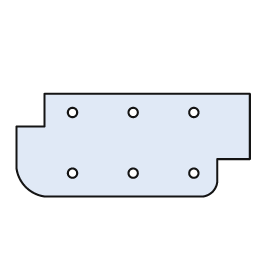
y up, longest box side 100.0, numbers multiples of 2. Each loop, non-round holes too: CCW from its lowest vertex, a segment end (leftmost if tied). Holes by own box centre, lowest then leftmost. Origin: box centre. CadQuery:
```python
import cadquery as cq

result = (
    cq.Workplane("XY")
    .moveTo(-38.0, -22.0)
    .lineTo(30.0, -22.0)
    .threePointArc((34.0, -20.0), (36.0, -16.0))
    .lineTo(36.0, -6.0)
    .lineTo(50.0, -6.0)
    .lineTo(50.0, 22.0)
    .lineTo(-38.0, 22.0)
    .lineTo(-38.0, 8.0)
    .lineTo(-50.0, 8.0)
    .lineTo(-50.0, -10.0)
    .threePointArc((-46.0, -18.0), (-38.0, -22.0))
    .close()
    .moveTo(-26.0, -12.0)
    .circle(2.0)
    .moveTo(0.0, -12.0)
    .circle(2.0)
    .moveTo(26.0, -12.0)
    .circle(2.0)
    .moveTo(-26.0, 14.0)
    .circle(2.0)
    .moveTo(0.0, 14.0)
    .circle(2.0)
    .moveTo(26.0, 14.0)
    .circle(2.0)
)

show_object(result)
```